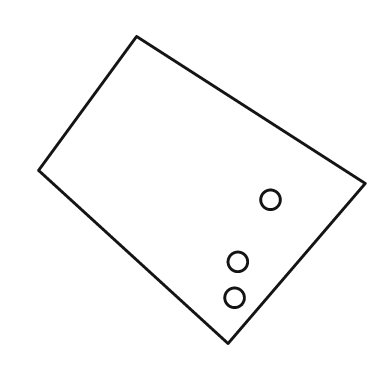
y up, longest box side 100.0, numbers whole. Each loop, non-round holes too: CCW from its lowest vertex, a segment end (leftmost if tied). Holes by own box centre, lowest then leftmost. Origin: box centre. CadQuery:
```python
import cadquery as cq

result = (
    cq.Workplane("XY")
    .moveTo(8.0, -47.0)
    .lineTo(50.0, 2.0)
    .lineTo(-20.0, 47.0)
    .lineTo(-50.0, 6.0)
    .close()
    .moveTo(10.0, -33.0)
    .circle(3.0)
    .moveTo(11.0, -22.0)
    .circle(3.0)
    .moveTo(21.0, -3.0)
    .circle(3.0)
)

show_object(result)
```